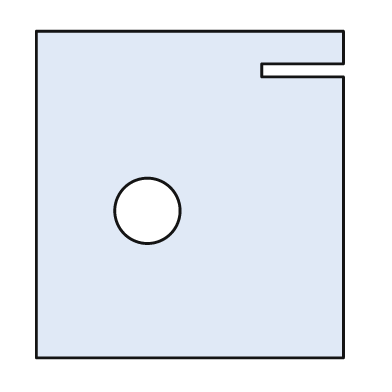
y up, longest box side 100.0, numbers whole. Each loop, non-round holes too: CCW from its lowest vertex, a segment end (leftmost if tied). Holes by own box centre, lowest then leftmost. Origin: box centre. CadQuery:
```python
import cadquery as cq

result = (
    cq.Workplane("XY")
    .moveTo(-47.0, -50.0)
    .lineTo(47.0, -50.0)
    .lineTo(47.0, 36.0)
    .lineTo(22.0, 36.0)
    .lineTo(22.0, 40.0)
    .lineTo(47.0, 40.0)
    .lineTo(47.0, 50.0)
    .lineTo(-47.0, 50.0)
    .close()
    .moveTo(-13.0, -5.0)
    .circle(10.0)
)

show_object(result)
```